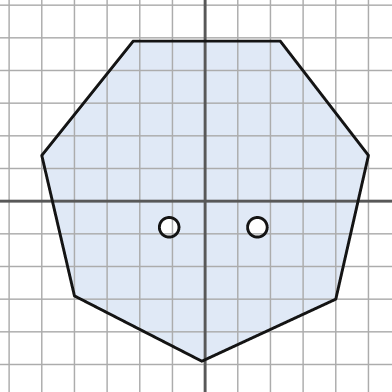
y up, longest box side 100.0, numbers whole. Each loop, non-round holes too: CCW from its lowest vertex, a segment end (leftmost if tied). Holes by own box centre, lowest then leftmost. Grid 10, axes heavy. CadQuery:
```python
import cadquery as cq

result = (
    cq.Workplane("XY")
    .moveTo(-1.0, -49.0)
    .lineTo(40.0, -30.0)
    .lineTo(50.0, 14.0)
    .lineTo(23.0, 49.0)
    .lineTo(-22.0, 49.0)
    .lineTo(-50.0, 14.0)
    .lineTo(-40.0, -29.0)
    .close()
    .moveTo(-11.0, -8.0)
    .circle(3.0)
    .moveTo(16.0, -8.0)
    .circle(3.0)
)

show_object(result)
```